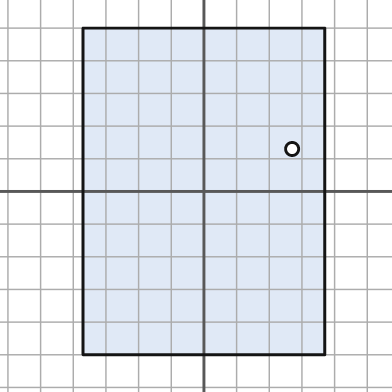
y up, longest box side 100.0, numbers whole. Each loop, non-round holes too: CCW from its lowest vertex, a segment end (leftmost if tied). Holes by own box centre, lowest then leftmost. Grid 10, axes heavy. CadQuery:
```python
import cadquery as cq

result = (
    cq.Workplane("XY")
    .moveTo(-37.0, -50.0)
    .lineTo(37.0, -50.0)
    .lineTo(37.0, 50.0)
    .lineTo(-37.0, 50.0)
    .close()
    .moveTo(27.0, 13.0)
    .circle(2.0)
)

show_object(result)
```